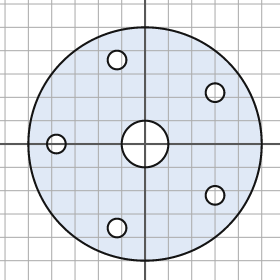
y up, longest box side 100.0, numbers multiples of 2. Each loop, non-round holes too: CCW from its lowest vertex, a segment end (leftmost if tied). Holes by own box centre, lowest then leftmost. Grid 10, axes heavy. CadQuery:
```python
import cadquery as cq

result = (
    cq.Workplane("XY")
    .moveTo(0.0, 0.0)
    .circle(50.0)
    .moveTo(-12.0, -36.0)
    .circle(4.0)
    .moveTo(30.0, -22.0)
    .circle(4.0)
    .moveTo(-38.0, 0.0)
    .circle(4.0)
    .moveTo(0.0, 0.0)
    .circle(10.0)
    .moveTo(30.0, 22.0)
    .circle(4.0)
    .moveTo(-12.0, 36.0)
    .circle(4.0)
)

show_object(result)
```